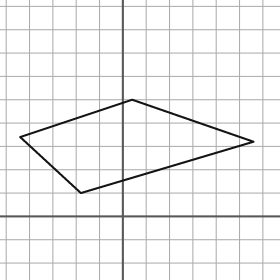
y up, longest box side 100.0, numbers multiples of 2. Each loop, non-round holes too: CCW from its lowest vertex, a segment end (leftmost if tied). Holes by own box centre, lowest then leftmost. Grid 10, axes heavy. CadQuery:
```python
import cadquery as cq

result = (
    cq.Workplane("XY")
    .moveTo(-18.0, 10.0)
    .lineTo(56.0, 32.0)
    .lineTo(4.0, 50.0)
    .lineTo(-44.0, 34.0)
    .close()
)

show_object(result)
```